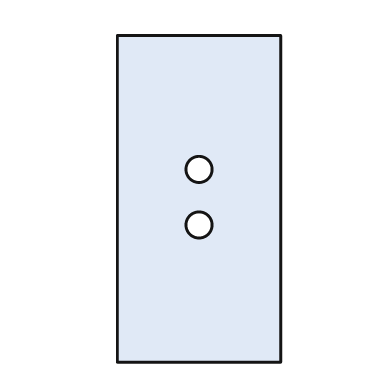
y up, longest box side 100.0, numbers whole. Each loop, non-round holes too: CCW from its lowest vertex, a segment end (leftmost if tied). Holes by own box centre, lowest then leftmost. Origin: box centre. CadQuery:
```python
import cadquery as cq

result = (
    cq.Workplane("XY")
    .moveTo(-25.0, -50.0)
    .lineTo(25.0, -50.0)
    .lineTo(25.0, 50.0)
    .lineTo(-25.0, 50.0)
    .close()
    .moveTo(0.0, -8.0)
    .circle(4.0)
    .moveTo(0.0, 9.0)
    .circle(4.0)
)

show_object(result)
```